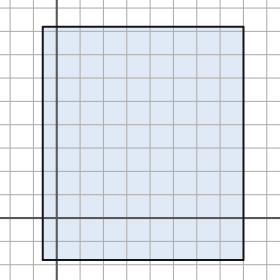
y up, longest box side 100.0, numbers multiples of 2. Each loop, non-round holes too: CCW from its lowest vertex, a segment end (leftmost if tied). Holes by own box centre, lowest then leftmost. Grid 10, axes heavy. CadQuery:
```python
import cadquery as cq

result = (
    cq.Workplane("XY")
    .moveTo(-6.0, -18.0)
    .lineTo(80.0, -18.0)
    .lineTo(80.0, 82.0)
    .lineTo(-6.0, 82.0)
    .close()
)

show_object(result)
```